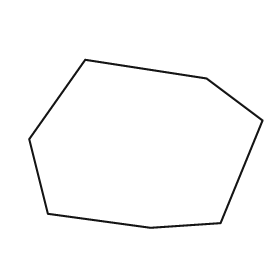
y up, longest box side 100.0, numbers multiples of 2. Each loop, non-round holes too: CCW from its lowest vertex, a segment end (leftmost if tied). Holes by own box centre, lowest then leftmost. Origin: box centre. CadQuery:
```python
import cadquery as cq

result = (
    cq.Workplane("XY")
    .moveTo(2.0, -36.0)
    .lineTo(32.0, -34.0)
    .lineTo(50.0, 10.0)
    .lineTo(26.0, 28.0)
    .lineTo(-26.0, 36.0)
    .lineTo(-50.0, 2.0)
    .lineTo(-42.0, -30.0)
    .close()
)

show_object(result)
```